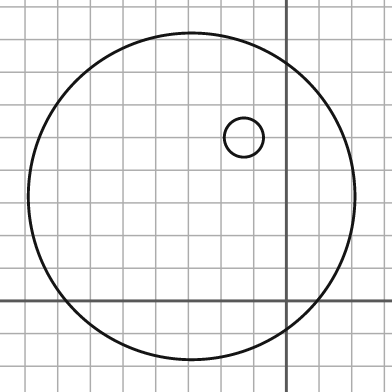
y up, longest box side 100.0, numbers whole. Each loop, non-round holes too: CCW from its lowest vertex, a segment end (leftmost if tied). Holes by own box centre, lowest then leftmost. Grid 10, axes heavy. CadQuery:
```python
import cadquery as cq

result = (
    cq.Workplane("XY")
    .moveTo(-29.0, 32.0)
    .circle(50.0)
    .moveTo(-13.0, 50.0)
    .circle(6.0)
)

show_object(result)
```